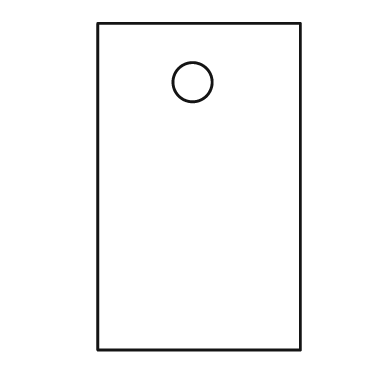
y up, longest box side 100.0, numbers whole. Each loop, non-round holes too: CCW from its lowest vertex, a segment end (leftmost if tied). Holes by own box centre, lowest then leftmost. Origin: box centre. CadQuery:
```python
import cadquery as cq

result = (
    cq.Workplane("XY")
    .moveTo(-31.0, -50.0)
    .lineTo(31.0, -50.0)
    .lineTo(31.0, 50.0)
    .lineTo(-31.0, 50.0)
    .close()
    .moveTo(-2.0, 32.0)
    .circle(6.0)
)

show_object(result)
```